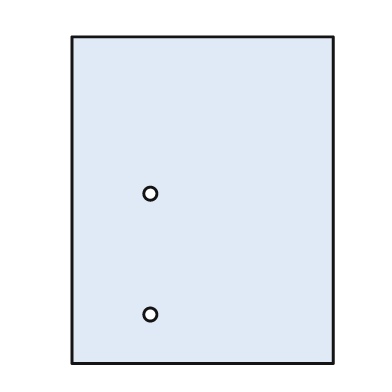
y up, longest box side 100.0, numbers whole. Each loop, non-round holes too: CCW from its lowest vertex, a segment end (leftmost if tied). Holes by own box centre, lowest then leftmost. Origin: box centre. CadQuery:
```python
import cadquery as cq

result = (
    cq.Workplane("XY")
    .moveTo(-40.0, -50.0)
    .lineTo(40.0, -50.0)
    .lineTo(40.0, 50.0)
    .lineTo(-40.0, 50.0)
    .close()
    .moveTo(-16.0, -35.0)
    .circle(2.0)
    .moveTo(-16.0, 2.0)
    .circle(2.0)
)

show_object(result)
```